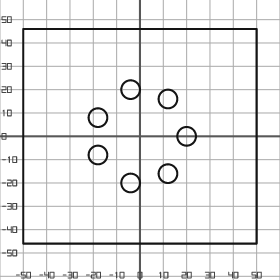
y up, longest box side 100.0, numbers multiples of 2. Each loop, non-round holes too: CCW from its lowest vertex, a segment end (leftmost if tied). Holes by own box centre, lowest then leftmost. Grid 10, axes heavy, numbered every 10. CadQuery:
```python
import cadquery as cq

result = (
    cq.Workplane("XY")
    .moveTo(-50.0, -46.0)
    .lineTo(50.0, -46.0)
    .lineTo(50.0, 46.0)
    .lineTo(-50.0, 46.0)
    .close()
    .moveTo(-4.0, -20.0)
    .circle(4.0)
    .moveTo(12.0, -16.0)
    .circle(4.0)
    .moveTo(-18.0, -8.0)
    .circle(4.0)
    .moveTo(20.0, 0.0)
    .circle(4.0)
    .moveTo(-18.0, 8.0)
    .circle(4.0)
    .moveTo(12.0, 16.0)
    .circle(4.0)
    .moveTo(-4.0, 20.0)
    .circle(4.0)
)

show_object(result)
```